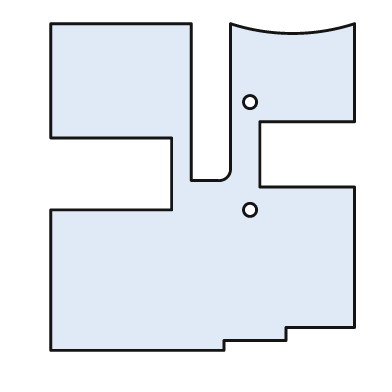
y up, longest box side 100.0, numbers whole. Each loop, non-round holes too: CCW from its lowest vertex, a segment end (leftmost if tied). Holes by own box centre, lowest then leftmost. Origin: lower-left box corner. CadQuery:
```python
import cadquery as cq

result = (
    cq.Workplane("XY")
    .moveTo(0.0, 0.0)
    .lineTo(53.0, 0.0)
    .lineTo(53.0, 3.0)
    .lineTo(72.0, 3.0)
    .lineTo(72.0, 7.0)
    .lineTo(93.0, 7.0)
    .lineTo(93.0, 50.0)
    .lineTo(64.0, 50.0)
    .lineTo(64.0, 70.0)
    .lineTo(93.0, 70.0)
    .lineTo(93.0, 100.0)
    .threePointArc((74.0, 97.0), (55.0, 100.0))
    .lineTo(55.0, 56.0)
    .threePointArc((54.0, 53.0), (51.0, 52.0))
    .lineTo(43.0, 52.0)
    .lineTo(43.0, 100.0)
    .lineTo(0.0, 100.0)
    .lineTo(0.0, 65.0)
    .lineTo(37.0, 65.0)
    .lineTo(37.0, 43.0)
    .lineTo(0.0, 43.0)
    .close()
    .moveTo(61.0, 43.0)
    .circle(2.0)
    .moveTo(61.0, 76.0)
    .circle(2.0)
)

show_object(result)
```